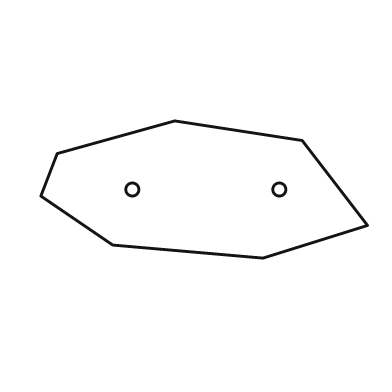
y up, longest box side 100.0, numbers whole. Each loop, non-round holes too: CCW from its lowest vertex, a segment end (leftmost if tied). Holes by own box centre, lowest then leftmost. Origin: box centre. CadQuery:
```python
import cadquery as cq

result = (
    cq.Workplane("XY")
    .moveTo(18.0, -21.0)
    .lineTo(50.0, -11.0)
    .lineTo(30.0, 15.0)
    .lineTo(-9.0, 21.0)
    .lineTo(-45.0, 11.0)
    .lineTo(-50.0, -2.0)
    .lineTo(-28.0, -17.0)
    .close()
    .moveTo(-22.0, 0.0)
    .circle(2.0)
    .moveTo(23.0, 0.0)
    .circle(2.0)
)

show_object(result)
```